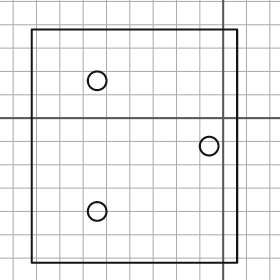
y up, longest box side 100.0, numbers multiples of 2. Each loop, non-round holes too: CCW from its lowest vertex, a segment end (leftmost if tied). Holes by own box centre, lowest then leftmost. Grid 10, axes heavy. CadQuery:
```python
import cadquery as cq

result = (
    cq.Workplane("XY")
    .moveTo(-82.0, -62.0)
    .lineTo(6.0, -62.0)
    .lineTo(6.0, 38.0)
    .lineTo(-82.0, 38.0)
    .close()
    .moveTo(-54.0, -40.0)
    .circle(4.0)
    .moveTo(-6.0, -12.0)
    .circle(4.0)
    .moveTo(-54.0, 16.0)
    .circle(4.0)
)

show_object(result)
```